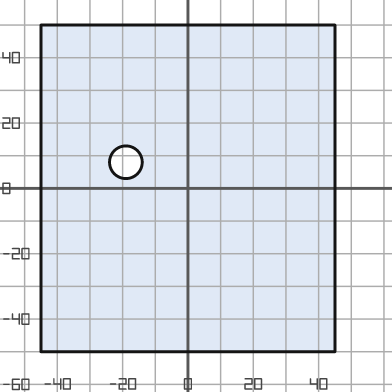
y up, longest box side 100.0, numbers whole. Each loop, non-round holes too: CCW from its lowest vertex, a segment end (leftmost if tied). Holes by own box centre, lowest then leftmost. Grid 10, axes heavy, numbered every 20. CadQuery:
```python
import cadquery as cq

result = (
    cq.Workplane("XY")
    .moveTo(-45.0, -50.0)
    .lineTo(45.0, -50.0)
    .lineTo(45.0, 50.0)
    .lineTo(-45.0, 50.0)
    .close()
    .moveTo(-19.0, 8.0)
    .circle(5.0)
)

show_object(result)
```